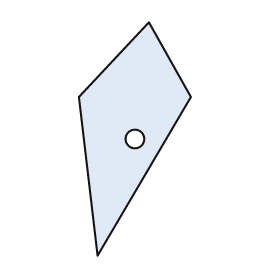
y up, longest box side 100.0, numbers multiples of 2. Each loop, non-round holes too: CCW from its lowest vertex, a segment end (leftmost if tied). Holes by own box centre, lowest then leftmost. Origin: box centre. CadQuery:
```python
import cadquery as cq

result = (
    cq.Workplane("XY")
    .moveTo(-16.0, -50.0)
    .lineTo(24.0, 18.0)
    .lineTo(6.0, 50.0)
    .lineTo(-24.0, 18.0)
    .close()
    .moveTo(0.0, 0.0)
    .circle(4.0)
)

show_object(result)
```